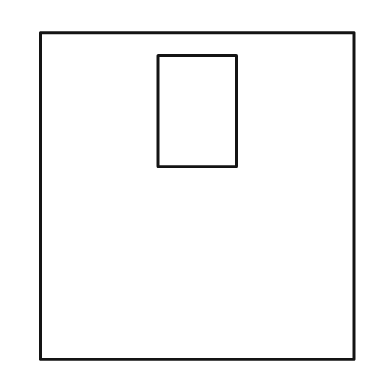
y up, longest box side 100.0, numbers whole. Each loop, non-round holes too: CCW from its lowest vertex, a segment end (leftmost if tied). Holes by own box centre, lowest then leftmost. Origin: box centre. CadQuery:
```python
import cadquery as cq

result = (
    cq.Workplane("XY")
    .moveTo(-48.0, -50.0)
    .lineTo(48.0, -50.0)
    .lineTo(48.0, 50.0)
    .lineTo(-48.0, 50.0)
    .close()
    .moveTo(-12.0, 9.0)
    .lineTo(12.0, 9.0)
    .lineTo(12.0, 43.0)
    .lineTo(-12.0, 43.0)
    .close()
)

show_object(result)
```